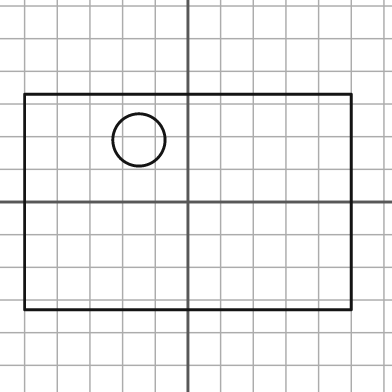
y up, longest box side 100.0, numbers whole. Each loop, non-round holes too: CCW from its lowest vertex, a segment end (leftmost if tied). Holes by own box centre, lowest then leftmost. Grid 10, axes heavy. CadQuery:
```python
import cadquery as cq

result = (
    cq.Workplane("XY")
    .moveTo(-50.0, -33.0)
    .lineTo(50.0, -33.0)
    .lineTo(50.0, 33.0)
    .lineTo(-50.0, 33.0)
    .close()
    .moveTo(-15.0, 19.0)
    .circle(8.0)
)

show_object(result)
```